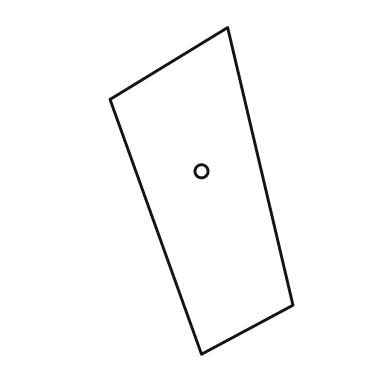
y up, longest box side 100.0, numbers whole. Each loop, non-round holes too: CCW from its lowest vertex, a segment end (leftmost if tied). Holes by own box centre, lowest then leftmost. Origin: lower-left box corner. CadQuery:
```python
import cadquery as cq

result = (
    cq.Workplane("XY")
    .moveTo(28.0, 0.0)
    .lineTo(56.0, 15.0)
    .lineTo(36.0, 100.0)
    .lineTo(0.0, 78.0)
    .close()
    .moveTo(28.0, 56.0)
    .circle(2.0)
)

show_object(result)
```